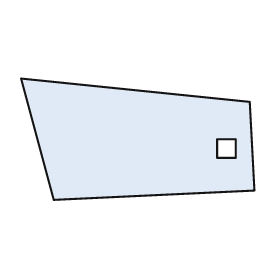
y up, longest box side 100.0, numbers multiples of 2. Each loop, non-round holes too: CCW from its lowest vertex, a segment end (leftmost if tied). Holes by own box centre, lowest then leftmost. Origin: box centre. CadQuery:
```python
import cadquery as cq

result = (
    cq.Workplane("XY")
    .moveTo(-36.0, -26.0)
    .lineTo(50.0, -22.0)
    .lineTo(48.0, 16.0)
    .lineTo(-50.0, 26.0)
    .close()
    .moveTo(34.0, -8.0)
    .lineTo(42.0, -8.0)
    .lineTo(42.0, 0.0)
    .lineTo(34.0, 0.0)
    .close()
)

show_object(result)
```